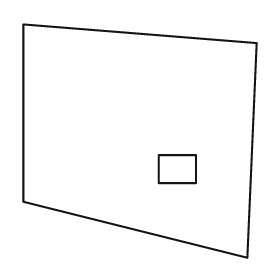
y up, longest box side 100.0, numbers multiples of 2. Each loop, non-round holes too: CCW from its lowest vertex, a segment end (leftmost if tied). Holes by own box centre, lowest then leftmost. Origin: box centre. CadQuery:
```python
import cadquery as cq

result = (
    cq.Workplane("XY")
    .moveTo(46.0, -50.0)
    .lineTo(50.0, 42.0)
    .lineTo(-50.0, 50.0)
    .lineTo(-50.0, -26.0)
    .close()
    .moveTo(8.0, -18.0)
    .lineTo(24.0, -18.0)
    .lineTo(24.0, -6.0)
    .lineTo(8.0, -6.0)
    .close()
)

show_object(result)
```